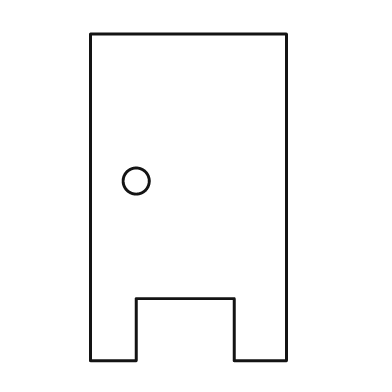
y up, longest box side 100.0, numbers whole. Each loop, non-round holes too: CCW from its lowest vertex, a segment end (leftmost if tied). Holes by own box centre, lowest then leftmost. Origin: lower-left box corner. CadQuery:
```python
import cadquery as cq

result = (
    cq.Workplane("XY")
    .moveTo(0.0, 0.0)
    .lineTo(14.0, 0.0)
    .lineTo(14.0, 19.0)
    .lineTo(44.0, 19.0)
    .lineTo(44.0, 0.0)
    .lineTo(60.0, 0.0)
    .lineTo(60.0, 100.0)
    .lineTo(0.0, 100.0)
    .close()
    .moveTo(14.0, 55.0)
    .circle(4.0)
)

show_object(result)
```